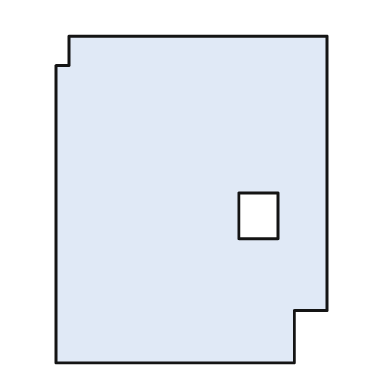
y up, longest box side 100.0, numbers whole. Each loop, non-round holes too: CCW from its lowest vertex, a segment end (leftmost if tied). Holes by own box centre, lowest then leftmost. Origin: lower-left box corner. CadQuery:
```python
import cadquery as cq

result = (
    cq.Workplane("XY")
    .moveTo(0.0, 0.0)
    .lineTo(73.0, 0.0)
    .lineTo(73.0, 16.0)
    .lineTo(83.0, 16.0)
    .lineTo(83.0, 100.0)
    .lineTo(4.0, 100.0)
    .lineTo(4.0, 91.0)
    .lineTo(0.0, 91.0)
    .close()
    .moveTo(56.0, 38.0)
    .lineTo(68.0, 38.0)
    .lineTo(68.0, 52.0)
    .lineTo(56.0, 52.0)
    .close()
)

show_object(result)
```